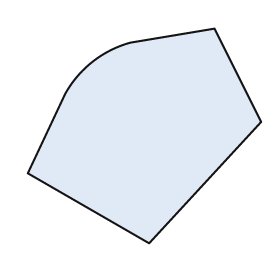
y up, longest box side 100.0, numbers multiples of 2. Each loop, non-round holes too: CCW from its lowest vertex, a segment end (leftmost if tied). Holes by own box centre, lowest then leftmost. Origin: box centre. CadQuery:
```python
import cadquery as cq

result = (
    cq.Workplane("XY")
    .moveTo(2.0, -46.0)
    .lineTo(50.0, 6.0)
    .lineTo(30.0, 46.0)
    .lineTo(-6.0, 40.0)
    .threePointArc((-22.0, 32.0), (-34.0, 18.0))
    .lineTo(-50.0, -16.0)
    .close()
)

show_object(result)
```